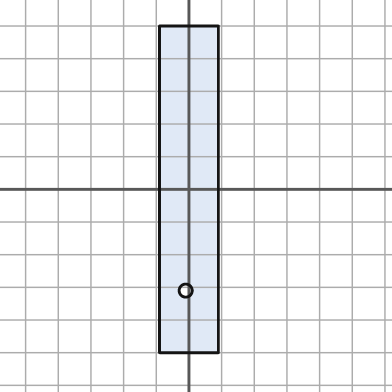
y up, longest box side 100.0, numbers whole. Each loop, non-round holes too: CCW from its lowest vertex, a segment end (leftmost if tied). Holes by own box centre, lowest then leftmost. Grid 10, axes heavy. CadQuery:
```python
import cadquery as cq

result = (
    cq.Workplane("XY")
    .moveTo(-9.0, -50.0)
    .lineTo(9.0, -50.0)
    .lineTo(9.0, 50.0)
    .lineTo(-9.0, 50.0)
    .close()
    .moveTo(-1.0, -31.0)
    .circle(2.0)
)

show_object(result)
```